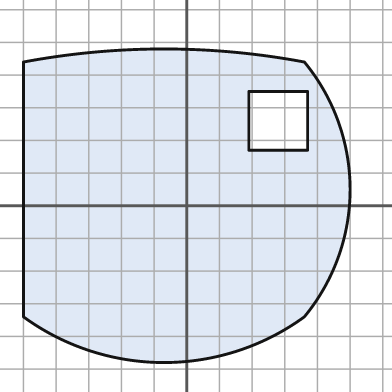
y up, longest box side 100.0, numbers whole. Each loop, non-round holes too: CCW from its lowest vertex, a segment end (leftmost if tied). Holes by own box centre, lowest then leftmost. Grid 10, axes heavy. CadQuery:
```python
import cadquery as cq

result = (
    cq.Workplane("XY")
    .moveTo(-50.0, -34.0)
    .threePointArc((-7.0, -48.0), (36.0, -34.0))
    .threePointArc((50.0, 5.0), (36.0, 44.0))
    .threePointArc((-7.0, 48.0), (-50.0, 44.0))
    .close()
    .moveTo(19.0, 17.0)
    .lineTo(37.0, 17.0)
    .lineTo(37.0, 35.0)
    .lineTo(19.0, 35.0)
    .close()
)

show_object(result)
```